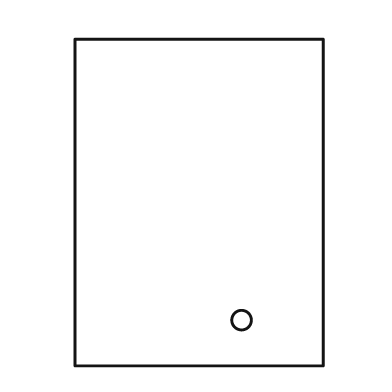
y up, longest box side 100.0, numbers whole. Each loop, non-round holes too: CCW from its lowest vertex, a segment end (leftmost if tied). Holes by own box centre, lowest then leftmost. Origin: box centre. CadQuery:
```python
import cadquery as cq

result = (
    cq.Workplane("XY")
    .moveTo(-38.0, -50.0)
    .lineTo(38.0, -50.0)
    .lineTo(38.0, 50.0)
    .lineTo(-38.0, 50.0)
    .close()
    .moveTo(13.0, -36.0)
    .circle(3.0)
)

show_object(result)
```